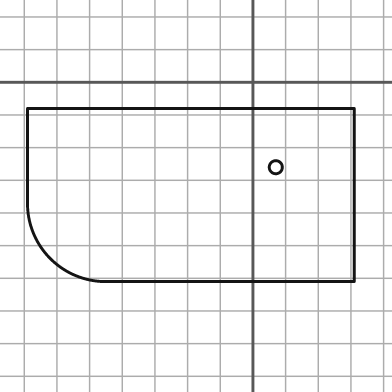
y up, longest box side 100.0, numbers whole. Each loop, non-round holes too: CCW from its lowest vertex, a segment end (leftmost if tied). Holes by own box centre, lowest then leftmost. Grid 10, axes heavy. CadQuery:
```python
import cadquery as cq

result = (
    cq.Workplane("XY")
    .moveTo(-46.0, -61.0)
    .lineTo(31.0, -61.0)
    .lineTo(31.0, -8.0)
    .lineTo(-69.0, -8.0)
    .lineTo(-69.0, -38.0)
    .threePointArc((-62.0, -54.0), (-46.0, -61.0))
    .close()
    .moveTo(7.0, -26.0)
    .circle(2.0)
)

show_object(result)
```